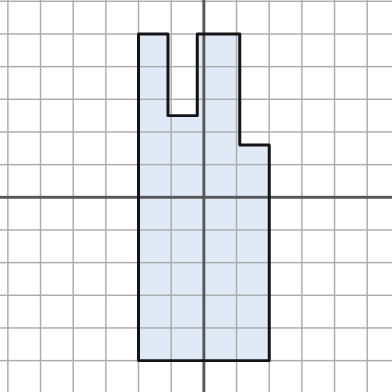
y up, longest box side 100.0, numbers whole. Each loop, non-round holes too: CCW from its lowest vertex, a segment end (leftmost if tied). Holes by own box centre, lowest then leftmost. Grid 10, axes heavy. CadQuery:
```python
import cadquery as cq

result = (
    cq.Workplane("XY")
    .moveTo(-20.0, -50.0)
    .lineTo(20.0, -50.0)
    .lineTo(20.0, 16.0)
    .lineTo(11.0, 16.0)
    .lineTo(11.0, 50.0)
    .lineTo(-2.0, 50.0)
    .lineTo(-2.0, 25.0)
    .lineTo(-11.0, 25.0)
    .lineTo(-11.0, 50.0)
    .lineTo(-20.0, 50.0)
    .close()
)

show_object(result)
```